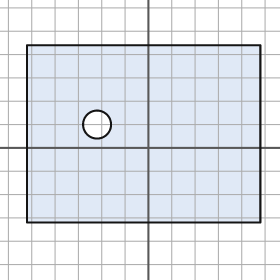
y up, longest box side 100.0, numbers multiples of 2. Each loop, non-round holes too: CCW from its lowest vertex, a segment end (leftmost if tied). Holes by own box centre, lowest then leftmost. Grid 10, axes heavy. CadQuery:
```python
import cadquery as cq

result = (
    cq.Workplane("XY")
    .moveTo(-52.0, -32.0)
    .lineTo(48.0, -32.0)
    .lineTo(48.0, 44.0)
    .lineTo(-52.0, 44.0)
    .close()
    .moveTo(-22.0, 10.0)
    .circle(6.0)
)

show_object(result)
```